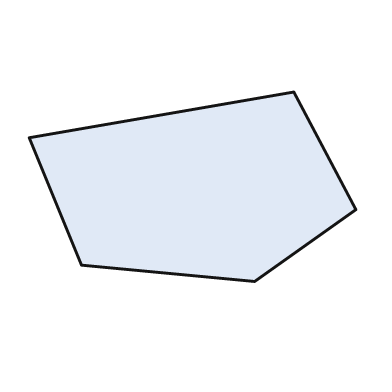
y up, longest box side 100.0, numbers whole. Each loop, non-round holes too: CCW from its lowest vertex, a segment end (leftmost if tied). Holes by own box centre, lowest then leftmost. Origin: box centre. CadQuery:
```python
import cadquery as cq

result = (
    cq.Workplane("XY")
    .moveTo(19.0, -29.0)
    .lineTo(50.0, -7.0)
    .lineTo(31.0, 29.0)
    .lineTo(-50.0, 15.0)
    .lineTo(-34.0, -24.0)
    .close()
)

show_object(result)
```